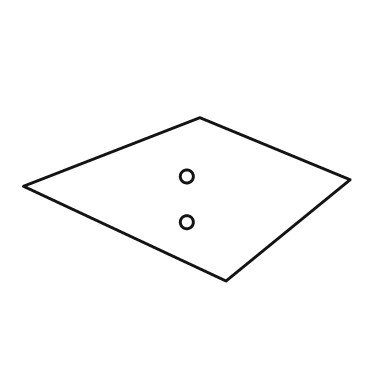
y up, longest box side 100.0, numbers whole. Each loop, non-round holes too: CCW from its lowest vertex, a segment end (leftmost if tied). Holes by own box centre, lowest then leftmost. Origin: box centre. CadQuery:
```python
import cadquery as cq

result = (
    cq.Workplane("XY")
    .moveTo(12.0, -25.0)
    .lineTo(50.0, 6.0)
    .lineTo(4.0, 25.0)
    .lineTo(-50.0, 4.0)
    .close()
    .moveTo(0.0, -7.0)
    .circle(2.0)
    .moveTo(0.0, 7.0)
    .circle(2.0)
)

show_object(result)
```